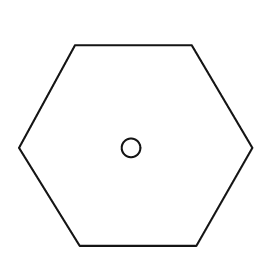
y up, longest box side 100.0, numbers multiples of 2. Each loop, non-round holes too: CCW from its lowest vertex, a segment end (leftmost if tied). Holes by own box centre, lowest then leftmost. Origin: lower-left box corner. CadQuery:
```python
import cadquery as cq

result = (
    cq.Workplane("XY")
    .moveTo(26.0, 0.0)
    .lineTo(76.0, 0.0)
    .lineTo(100.0, 42.0)
    .lineTo(74.0, 86.0)
    .lineTo(24.0, 86.0)
    .lineTo(0.0, 42.0)
    .close()
    .moveTo(48.0, 42.0)
    .circle(4.0)
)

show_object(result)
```